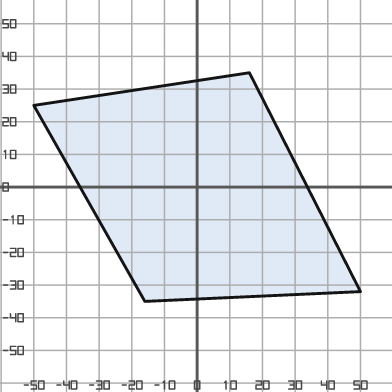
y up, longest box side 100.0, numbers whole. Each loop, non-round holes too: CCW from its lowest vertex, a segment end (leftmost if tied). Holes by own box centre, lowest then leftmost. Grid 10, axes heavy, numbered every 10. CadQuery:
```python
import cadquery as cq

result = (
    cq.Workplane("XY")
    .moveTo(-16.0, -35.0)
    .lineTo(50.0, -32.0)
    .lineTo(16.0, 35.0)
    .lineTo(-50.0, 25.0)
    .close()
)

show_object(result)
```